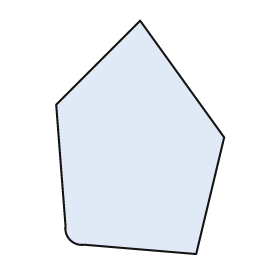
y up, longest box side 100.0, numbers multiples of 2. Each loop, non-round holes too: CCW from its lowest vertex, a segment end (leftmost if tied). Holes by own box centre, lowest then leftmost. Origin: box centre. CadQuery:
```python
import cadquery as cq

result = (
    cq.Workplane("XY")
    .moveTo(24.0, -50.0)
    .lineTo(36.0, 0.0)
    .lineTo(0.0, 50.0)
    .lineTo(-36.0, 14.0)
    .lineTo(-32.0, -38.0)
    .threePointArc((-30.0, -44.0), (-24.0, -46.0))
    .close()
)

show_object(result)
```